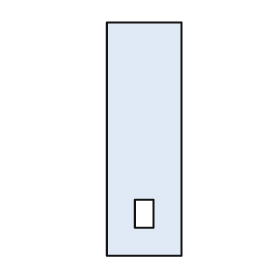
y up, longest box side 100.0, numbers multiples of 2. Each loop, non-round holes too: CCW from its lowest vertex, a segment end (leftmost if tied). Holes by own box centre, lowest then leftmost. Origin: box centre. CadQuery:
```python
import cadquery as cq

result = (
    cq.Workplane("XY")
    .moveTo(-16.0, -50.0)
    .lineTo(16.0, -50.0)
    .lineTo(16.0, 50.0)
    .lineTo(-16.0, 50.0)
    .close()
    .moveTo(-4.0, -38.0)
    .lineTo(4.0, -38.0)
    .lineTo(4.0, -26.0)
    .lineTo(-4.0, -26.0)
    .close()
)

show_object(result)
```